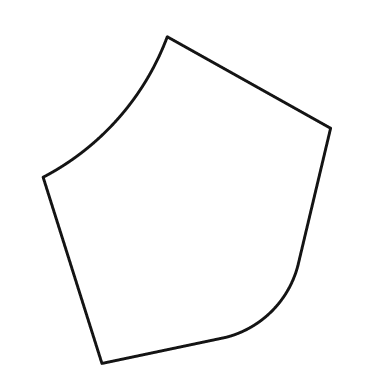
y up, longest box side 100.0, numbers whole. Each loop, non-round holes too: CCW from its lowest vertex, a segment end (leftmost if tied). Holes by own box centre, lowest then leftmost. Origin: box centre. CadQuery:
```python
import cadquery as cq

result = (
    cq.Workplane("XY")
    .moveTo(-26.0, -50.0)
    .lineTo(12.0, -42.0)
    .threePointArc((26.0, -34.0), (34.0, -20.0))
    .lineTo(44.0, 22.0)
    .lineTo(-6.0, 50.0)
    .threePointArc((-21.0, 25.0), (-44.0, 7.0))
    .close()
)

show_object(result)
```